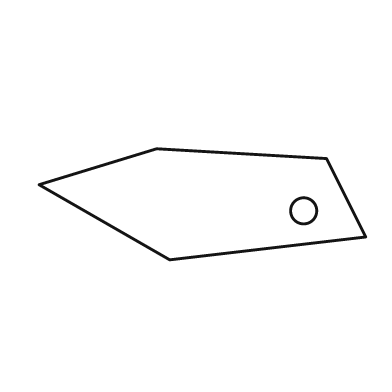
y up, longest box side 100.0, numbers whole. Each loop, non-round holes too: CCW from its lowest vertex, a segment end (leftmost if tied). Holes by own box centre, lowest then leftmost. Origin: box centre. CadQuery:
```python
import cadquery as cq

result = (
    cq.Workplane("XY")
    .moveTo(-10.0, -17.0)
    .lineTo(50.0, -10.0)
    .lineTo(38.0, 14.0)
    .lineTo(-14.0, 17.0)
    .lineTo(-50.0, 6.0)
    .close()
    .moveTo(31.0, -2.0)
    .circle(4.0)
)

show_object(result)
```